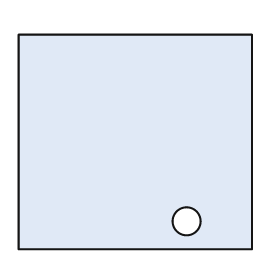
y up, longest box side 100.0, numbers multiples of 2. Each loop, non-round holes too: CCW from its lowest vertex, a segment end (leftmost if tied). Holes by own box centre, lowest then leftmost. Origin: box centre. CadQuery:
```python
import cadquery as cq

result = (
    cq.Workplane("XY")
    .moveTo(-50.0, -46.0)
    .lineTo(50.0, -46.0)
    .lineTo(50.0, 46.0)
    .lineTo(-50.0, 46.0)
    .close()
    .moveTo(22.0, -34.0)
    .circle(6.0)
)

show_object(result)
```